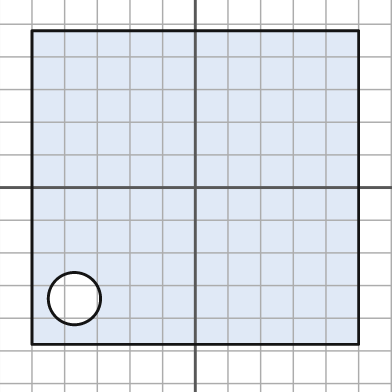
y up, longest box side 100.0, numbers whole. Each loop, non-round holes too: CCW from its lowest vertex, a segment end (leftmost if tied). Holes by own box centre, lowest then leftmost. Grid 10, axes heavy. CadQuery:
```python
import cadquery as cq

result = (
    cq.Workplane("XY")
    .moveTo(-50.0, -48.0)
    .lineTo(50.0, -48.0)
    .lineTo(50.0, 48.0)
    .lineTo(-50.0, 48.0)
    .close()
    .moveTo(-37.0, -34.0)
    .circle(8.0)
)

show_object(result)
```